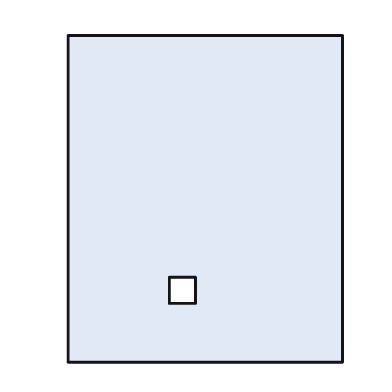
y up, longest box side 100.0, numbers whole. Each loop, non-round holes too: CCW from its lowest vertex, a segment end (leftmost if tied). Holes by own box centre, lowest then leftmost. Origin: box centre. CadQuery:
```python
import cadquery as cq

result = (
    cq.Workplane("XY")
    .moveTo(-42.0, -50.0)
    .lineTo(42.0, -50.0)
    .lineTo(42.0, 50.0)
    .lineTo(-42.0, 50.0)
    .close()
    .moveTo(-11.0, -32.0)
    .lineTo(-3.0, -32.0)
    .lineTo(-3.0, -24.0)
    .lineTo(-11.0, -24.0)
    .close()
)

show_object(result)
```